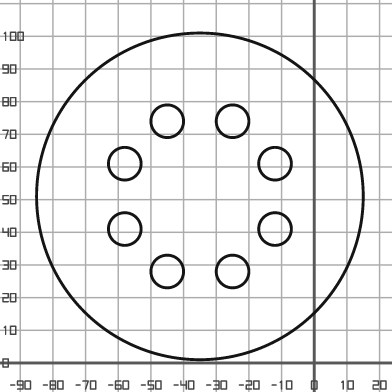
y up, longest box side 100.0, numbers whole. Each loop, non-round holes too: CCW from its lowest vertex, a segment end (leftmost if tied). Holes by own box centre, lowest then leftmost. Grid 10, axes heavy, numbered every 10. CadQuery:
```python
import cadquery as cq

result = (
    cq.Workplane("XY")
    .moveTo(-35.0, 51.0)
    .circle(50.0)
    .moveTo(-45.0, 28.0)
    .circle(5.0)
    .moveTo(-25.0, 28.0)
    .circle(5.0)
    .moveTo(-58.0, 41.0)
    .circle(5.0)
    .moveTo(-12.0, 41.0)
    .circle(5.0)
    .moveTo(-58.0, 61.0)
    .circle(5.0)
    .moveTo(-12.0, 61.0)
    .circle(5.0)
    .moveTo(-45.0, 74.0)
    .circle(5.0)
    .moveTo(-25.0, 74.0)
    .circle(5.0)
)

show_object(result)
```